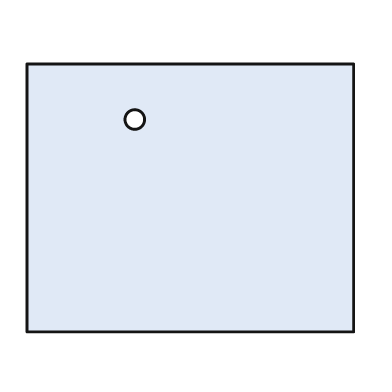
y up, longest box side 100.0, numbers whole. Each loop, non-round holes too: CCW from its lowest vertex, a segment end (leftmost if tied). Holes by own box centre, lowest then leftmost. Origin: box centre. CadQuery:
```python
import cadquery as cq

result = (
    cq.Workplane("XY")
    .moveTo(-50.0, -41.0)
    .lineTo(50.0, -41.0)
    .lineTo(50.0, 41.0)
    .lineTo(-50.0, 41.0)
    .close()
    .moveTo(-17.0, 24.0)
    .circle(3.0)
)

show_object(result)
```